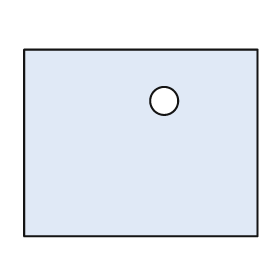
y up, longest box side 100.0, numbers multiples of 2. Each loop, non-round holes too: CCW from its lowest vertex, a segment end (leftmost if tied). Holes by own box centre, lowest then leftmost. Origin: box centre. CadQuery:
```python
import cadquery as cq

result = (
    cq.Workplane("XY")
    .moveTo(-50.0, -40.0)
    .lineTo(50.0, -40.0)
    .lineTo(50.0, 40.0)
    .lineTo(-50.0, 40.0)
    .close()
    .moveTo(10.0, 18.0)
    .circle(6.0)
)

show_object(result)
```